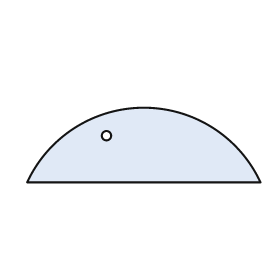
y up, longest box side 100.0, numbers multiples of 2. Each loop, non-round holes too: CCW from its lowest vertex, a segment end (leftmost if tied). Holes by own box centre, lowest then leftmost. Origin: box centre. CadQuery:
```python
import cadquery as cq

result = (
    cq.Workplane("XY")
    .moveTo(-50.0, -16.0)
    .lineTo(50.0, -16.0)
    .threePointArc((0.0, 16.0), (-50.0, -16.0))
    .close()
    .moveTo(-16.0, 4.0)
    .circle(2.0)
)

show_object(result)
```